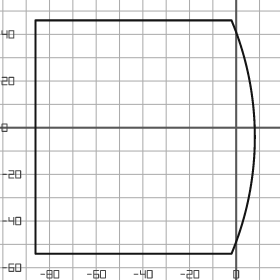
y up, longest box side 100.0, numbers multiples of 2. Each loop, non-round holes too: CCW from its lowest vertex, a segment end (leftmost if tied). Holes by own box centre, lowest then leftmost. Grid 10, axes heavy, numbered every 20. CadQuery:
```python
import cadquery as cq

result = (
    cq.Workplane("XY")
    .moveTo(-86.0, -54.0)
    .lineTo(-2.0, -54.0)
    .threePointArc((8.0, -4.0), (-2.0, 46.0))
    .lineTo(-86.0, 46.0)
    .close()
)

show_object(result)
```